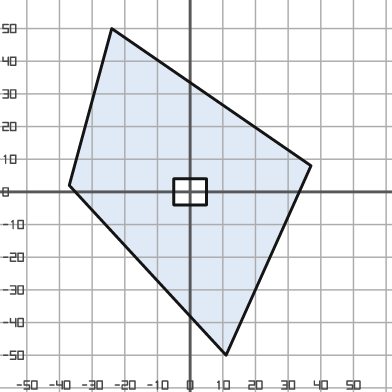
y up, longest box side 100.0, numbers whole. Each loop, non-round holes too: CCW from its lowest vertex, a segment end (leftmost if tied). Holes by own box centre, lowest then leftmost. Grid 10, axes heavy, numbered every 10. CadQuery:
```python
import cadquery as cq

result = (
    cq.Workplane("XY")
    .moveTo(11.0, -50.0)
    .lineTo(37.0, 8.0)
    .lineTo(-24.0, 50.0)
    .lineTo(-37.0, 2.0)
    .close()
    .moveTo(-5.0, -4.0)
    .lineTo(5.0, -4.0)
    .lineTo(5.0, 4.0)
    .lineTo(-5.0, 4.0)
    .close()
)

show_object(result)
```